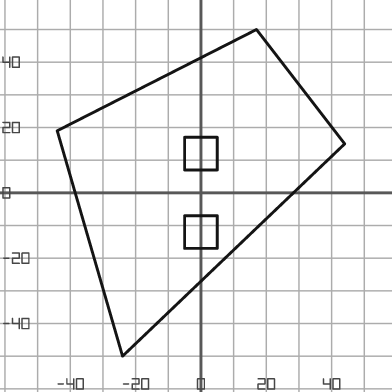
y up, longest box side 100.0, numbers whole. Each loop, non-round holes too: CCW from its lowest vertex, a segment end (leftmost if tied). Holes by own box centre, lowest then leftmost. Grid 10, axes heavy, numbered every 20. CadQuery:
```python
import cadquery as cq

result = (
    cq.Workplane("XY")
    .moveTo(-24.0, -50.0)
    .lineTo(44.0, 15.0)
    .lineTo(17.0, 50.0)
    .lineTo(-44.0, 19.0)
    .close()
    .moveTo(-5.0, -17.0)
    .lineTo(5.0, -17.0)
    .lineTo(5.0, -7.0)
    .lineTo(-5.0, -7.0)
    .close()
    .moveTo(-5.0, 7.0)
    .lineTo(5.0, 7.0)
    .lineTo(5.0, 17.0)
    .lineTo(-5.0, 17.0)
    .close()
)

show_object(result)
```